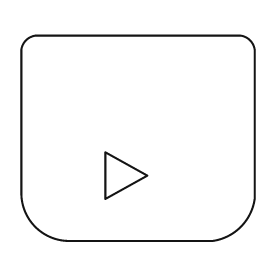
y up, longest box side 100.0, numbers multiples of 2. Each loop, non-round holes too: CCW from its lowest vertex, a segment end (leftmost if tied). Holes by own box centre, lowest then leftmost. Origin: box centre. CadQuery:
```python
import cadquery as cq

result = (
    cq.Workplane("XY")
    .moveTo(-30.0, -44.0)
    .lineTo(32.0, -44.0)
    .threePointArc((44.0, -38.0), (50.0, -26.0))
    .lineTo(50.0, 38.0)
    .threePointArc((48.0, 42.0), (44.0, 44.0))
    .lineTo(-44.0, 44.0)
    .threePointArc((-48.0, 42.0), (-50.0, 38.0))
    .lineTo(-50.0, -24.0)
    .threePointArc((-44.0, -38.0), (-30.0, -44.0))
    .close()
    .moveTo(-14.0, -26.0)
    .lineTo(4.0, -16.0)
    .lineTo(-14.0, -6.0)
    .close()
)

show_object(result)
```